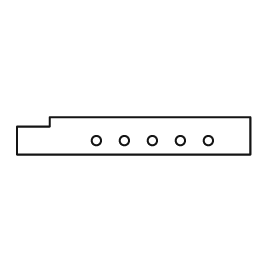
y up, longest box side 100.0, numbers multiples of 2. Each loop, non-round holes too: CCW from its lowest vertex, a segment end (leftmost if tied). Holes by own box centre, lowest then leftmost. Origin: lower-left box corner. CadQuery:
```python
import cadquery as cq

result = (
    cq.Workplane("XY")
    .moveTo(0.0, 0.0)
    .lineTo(100.0, 0.0)
    .lineTo(100.0, 16.0)
    .lineTo(14.0, 16.0)
    .lineTo(14.0, 12.0)
    .lineTo(0.0, 12.0)
    .close()
    .moveTo(34.0, 6.0)
    .circle(2.0)
    .moveTo(46.0, 6.0)
    .circle(2.0)
    .moveTo(58.0, 6.0)
    .circle(2.0)
    .moveTo(70.0, 6.0)
    .circle(2.0)
    .moveTo(82.0, 6.0)
    .circle(2.0)
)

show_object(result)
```